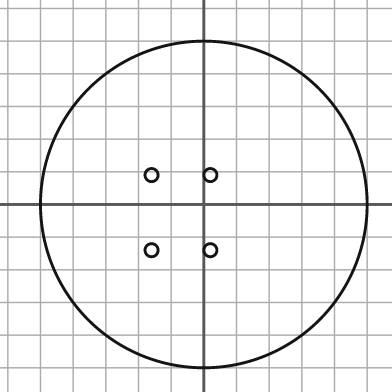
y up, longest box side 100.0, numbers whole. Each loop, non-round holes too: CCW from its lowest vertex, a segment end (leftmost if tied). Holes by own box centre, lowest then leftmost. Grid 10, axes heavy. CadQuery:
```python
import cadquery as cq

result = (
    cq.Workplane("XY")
    .moveTo(0.0, 0.0)
    .circle(50.0)
    .moveTo(-16.0, -14.0)
    .circle(2.0)
    .moveTo(2.0, -14.0)
    .circle(2.0)
    .moveTo(-16.0, 9.0)
    .circle(2.0)
    .moveTo(2.0, 9.0)
    .circle(2.0)
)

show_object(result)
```